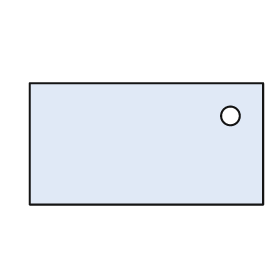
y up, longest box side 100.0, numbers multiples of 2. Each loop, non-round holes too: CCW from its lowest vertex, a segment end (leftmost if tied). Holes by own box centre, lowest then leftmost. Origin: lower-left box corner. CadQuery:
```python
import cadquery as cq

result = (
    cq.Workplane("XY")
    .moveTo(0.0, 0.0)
    .lineTo(100.0, 0.0)
    .lineTo(100.0, 52.0)
    .lineTo(0.0, 52.0)
    .close()
    .moveTo(86.0, 38.0)
    .circle(4.0)
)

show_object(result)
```